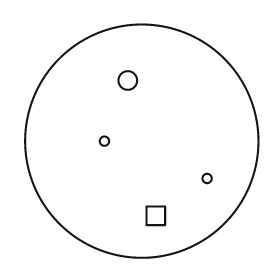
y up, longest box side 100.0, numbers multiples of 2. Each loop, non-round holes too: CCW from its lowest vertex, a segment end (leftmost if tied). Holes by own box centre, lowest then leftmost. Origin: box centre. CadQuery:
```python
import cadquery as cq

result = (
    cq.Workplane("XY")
    .moveTo(0.0, 0.0)
    .circle(50.0)
    .moveTo(2.0, -36.0)
    .lineTo(10.0, -36.0)
    .lineTo(10.0, -28.0)
    .lineTo(2.0, -28.0)
    .close()
    .moveTo(28.0, -16.0)
    .circle(2.0)
    .moveTo(-16.0, 0.0)
    .circle(2.0)
    .moveTo(-6.0, 26.0)
    .circle(4.0)
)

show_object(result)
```